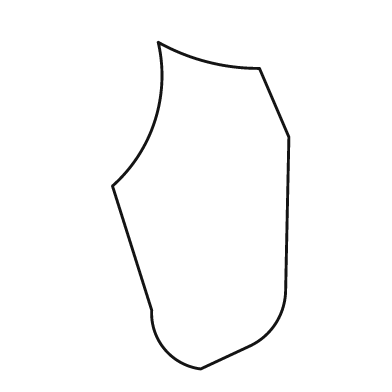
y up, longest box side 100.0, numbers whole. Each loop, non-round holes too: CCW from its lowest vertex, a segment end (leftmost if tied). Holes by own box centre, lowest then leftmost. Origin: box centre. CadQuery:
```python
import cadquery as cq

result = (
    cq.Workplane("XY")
    .moveTo(0.0, -50.0)
    .lineTo(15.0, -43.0)
    .threePointArc((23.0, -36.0), (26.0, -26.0))
    .lineTo(27.0, 21.0)
    .lineTo(18.0, 42.0)
    .threePointArc((2.0, 44.0), (-13.0, 50.0))
    .threePointArc((-14.0, 26.0), (-27.0, 6.0))
    .lineTo(-15.0, -32.0)
    .threePointArc((-11.0, -44.0), (0.0, -50.0))
    .close()
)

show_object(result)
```